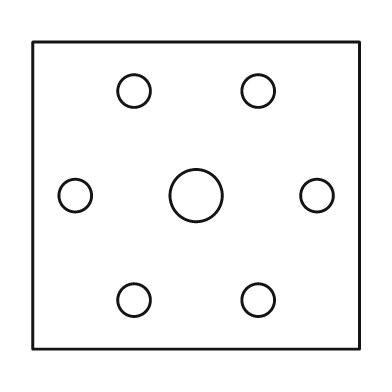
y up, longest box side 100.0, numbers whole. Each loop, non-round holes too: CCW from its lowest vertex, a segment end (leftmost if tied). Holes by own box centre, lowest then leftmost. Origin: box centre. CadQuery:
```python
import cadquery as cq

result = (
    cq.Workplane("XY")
    .moveTo(-50.0, -47.0)
    .lineTo(50.0, -47.0)
    .lineTo(50.0, 47.0)
    .lineTo(-50.0, 47.0)
    .close()
    .moveTo(-19.0, -32.0)
    .circle(5.0)
    .moveTo(19.0, -32.0)
    .circle(5.0)
    .moveTo(-37.0, 0.0)
    .circle(5.0)
    .moveTo(0.0, 0.0)
    .circle(8.0)
    .moveTo(37.0, 0.0)
    .circle(5.0)
    .moveTo(-19.0, 32.0)
    .circle(5.0)
    .moveTo(19.0, 32.0)
    .circle(5.0)
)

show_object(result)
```